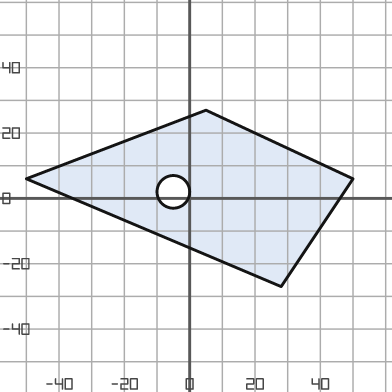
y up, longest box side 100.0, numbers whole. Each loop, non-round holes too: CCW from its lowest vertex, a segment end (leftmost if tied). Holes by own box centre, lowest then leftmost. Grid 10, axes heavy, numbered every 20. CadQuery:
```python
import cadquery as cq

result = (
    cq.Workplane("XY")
    .moveTo(28.0, -27.0)
    .lineTo(50.0, 6.0)
    .lineTo(5.0, 27.0)
    .lineTo(-50.0, 6.0)
    .close()
    .moveTo(-5.0, 2.0)
    .circle(5.0)
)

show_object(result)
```